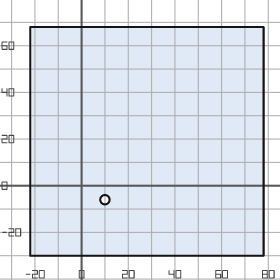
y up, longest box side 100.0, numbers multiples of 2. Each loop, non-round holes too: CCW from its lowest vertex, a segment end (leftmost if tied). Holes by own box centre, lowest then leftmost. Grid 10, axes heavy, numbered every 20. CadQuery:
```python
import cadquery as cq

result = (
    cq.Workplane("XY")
    .moveTo(-22.0, -30.0)
    .lineTo(78.0, -30.0)
    .lineTo(78.0, 68.0)
    .lineTo(-22.0, 68.0)
    .close()
    .moveTo(10.0, -6.0)
    .circle(2.0)
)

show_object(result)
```